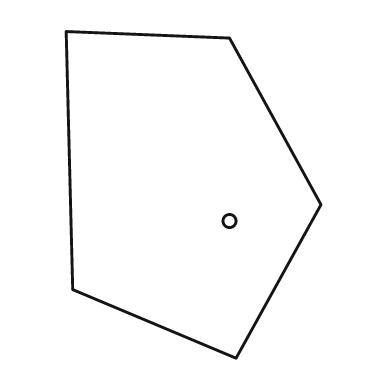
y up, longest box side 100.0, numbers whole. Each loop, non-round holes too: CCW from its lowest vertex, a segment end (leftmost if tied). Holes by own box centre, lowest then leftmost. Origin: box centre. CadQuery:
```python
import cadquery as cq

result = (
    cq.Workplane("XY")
    .moveTo(13.0, -50.0)
    .lineTo(39.0, -3.0)
    .lineTo(11.0, 48.0)
    .lineTo(-39.0, 50.0)
    .lineTo(-37.0, -29.0)
    .close()
    .moveTo(11.0, -8.0)
    .circle(2.0)
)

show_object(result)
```